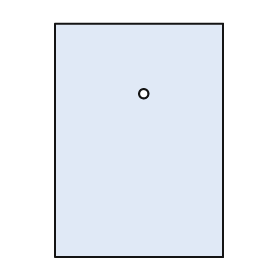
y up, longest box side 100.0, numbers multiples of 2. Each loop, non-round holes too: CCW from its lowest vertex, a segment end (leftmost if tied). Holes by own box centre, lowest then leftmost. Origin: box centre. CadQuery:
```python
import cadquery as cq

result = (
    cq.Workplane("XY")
    .moveTo(-36.0, -50.0)
    .lineTo(36.0, -50.0)
    .lineTo(36.0, 50.0)
    .lineTo(-36.0, 50.0)
    .close()
    .moveTo(2.0, 20.0)
    .circle(2.0)
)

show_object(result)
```